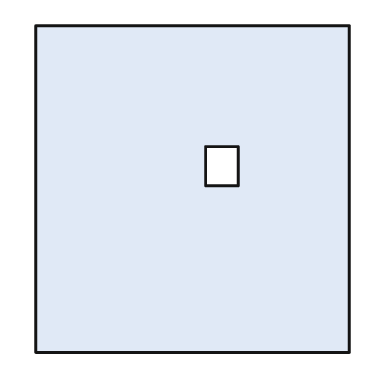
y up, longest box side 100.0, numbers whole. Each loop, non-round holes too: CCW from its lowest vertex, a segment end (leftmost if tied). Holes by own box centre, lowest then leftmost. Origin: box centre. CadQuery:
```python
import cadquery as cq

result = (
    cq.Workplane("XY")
    .moveTo(-48.0, -50.0)
    .lineTo(48.0, -50.0)
    .lineTo(48.0, 50.0)
    .lineTo(-48.0, 50.0)
    .close()
    .moveTo(4.0, 1.0)
    .lineTo(14.0, 1.0)
    .lineTo(14.0, 13.0)
    .lineTo(4.0, 13.0)
    .close()
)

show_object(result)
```